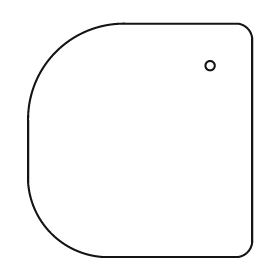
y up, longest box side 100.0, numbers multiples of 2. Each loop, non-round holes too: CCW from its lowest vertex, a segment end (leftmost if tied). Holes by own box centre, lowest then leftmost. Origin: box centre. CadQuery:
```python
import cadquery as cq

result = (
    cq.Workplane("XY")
    .moveTo(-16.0, -50.0)
    .lineTo(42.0, -50.0)
    .threePointArc((46.0, -48.0), (48.0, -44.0))
    .lineTo(48.0, 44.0)
    .threePointArc((46.0, 48.0), (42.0, 50.0))
    .lineTo(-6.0, 50.0)
    .threePointArc((-36.0, 38.0), (-48.0, 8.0))
    .lineTo(-48.0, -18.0)
    .threePointArc((-38.0, -40.0), (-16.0, -50.0))
    .close()
    .moveTo(30.0, 32.0)
    .circle(2.0)
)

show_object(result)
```